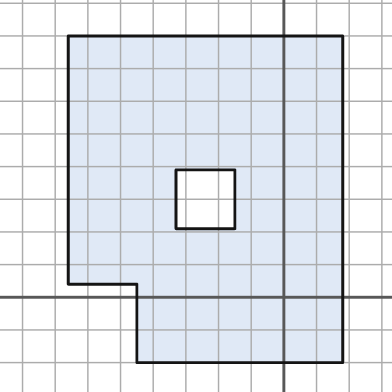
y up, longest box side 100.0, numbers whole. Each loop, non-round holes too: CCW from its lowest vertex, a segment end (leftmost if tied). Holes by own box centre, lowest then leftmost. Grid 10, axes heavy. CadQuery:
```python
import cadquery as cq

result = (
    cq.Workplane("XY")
    .moveTo(-45.0, -20.0)
    .lineTo(18.0, -20.0)
    .lineTo(18.0, 80.0)
    .lineTo(-66.0, 80.0)
    .lineTo(-66.0, 4.0)
    .lineTo(-45.0, 4.0)
    .close()
    .moveTo(-33.0, 21.0)
    .lineTo(-15.0, 21.0)
    .lineTo(-15.0, 39.0)
    .lineTo(-33.0, 39.0)
    .close()
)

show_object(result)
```